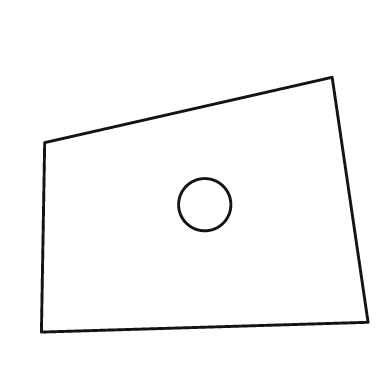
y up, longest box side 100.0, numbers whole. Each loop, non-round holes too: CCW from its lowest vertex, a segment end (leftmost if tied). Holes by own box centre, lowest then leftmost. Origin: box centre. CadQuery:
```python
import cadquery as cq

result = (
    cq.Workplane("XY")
    .moveTo(-50.0, -39.0)
    .lineTo(50.0, -36.0)
    .lineTo(39.0, 39.0)
    .lineTo(-49.0, 19.0)
    .close()
    .moveTo(0.0, 0.0)
    .circle(8.0)
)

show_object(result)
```